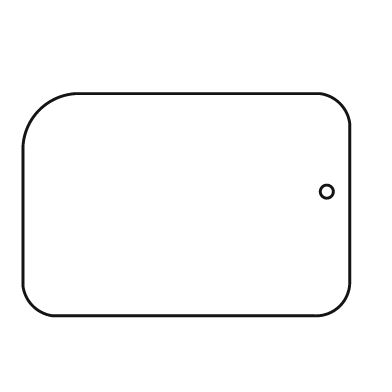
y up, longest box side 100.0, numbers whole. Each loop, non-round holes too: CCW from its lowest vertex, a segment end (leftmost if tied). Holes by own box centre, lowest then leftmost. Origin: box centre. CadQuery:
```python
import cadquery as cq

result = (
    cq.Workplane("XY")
    .moveTo(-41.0, -34.0)
    .lineTo(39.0, -34.0)
    .threePointArc((47.0, -31.0), (50.0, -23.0))
    .lineTo(50.0, 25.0)
    .threePointArc((47.0, 31.0), (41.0, 34.0))
    .lineTo(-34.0, 34.0)
    .threePointArc((-45.0, 29.0), (-50.0, 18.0))
    .lineTo(-50.0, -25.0)
    .threePointArc((-47.0, -31.0), (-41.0, -34.0))
    .close()
    .moveTo(43.0, 4.0)
    .circle(2.0)
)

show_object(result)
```